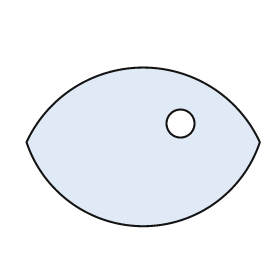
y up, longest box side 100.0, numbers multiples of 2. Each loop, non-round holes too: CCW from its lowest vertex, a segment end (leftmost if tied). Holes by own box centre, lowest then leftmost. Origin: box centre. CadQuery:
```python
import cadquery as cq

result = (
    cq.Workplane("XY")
    .moveTo(-50.0, 2.0)
    .threePointArc((0.0, -34.0), (50.0, 2.0))
    .threePointArc((0.0, 34.0), (-50.0, 2.0))
    .close()
    .moveTo(16.0, 10.0)
    .circle(6.0)
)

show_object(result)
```